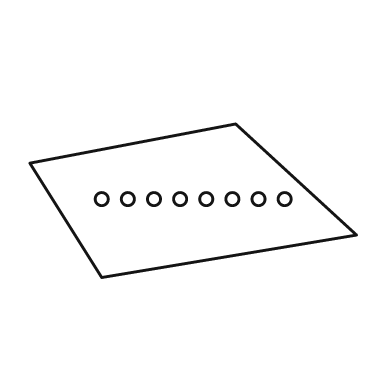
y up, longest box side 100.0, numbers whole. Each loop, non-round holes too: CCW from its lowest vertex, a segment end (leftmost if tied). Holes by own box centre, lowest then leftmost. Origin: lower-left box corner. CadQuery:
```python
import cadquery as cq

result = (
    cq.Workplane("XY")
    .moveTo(22.0, 0.0)
    .lineTo(100.0, 13.0)
    .lineTo(63.0, 47.0)
    .lineTo(0.0, 35.0)
    .close()
    .moveTo(22.0, 24.0)
    .circle(2.0)
    .moveTo(30.0, 24.0)
    .circle(2.0)
    .moveTo(38.0, 24.0)
    .circle(2.0)
    .moveTo(46.0, 24.0)
    .circle(2.0)
    .moveTo(54.0, 24.0)
    .circle(2.0)
    .moveTo(62.0, 24.0)
    .circle(2.0)
    .moveTo(70.0, 24.0)
    .circle(2.0)
    .moveTo(78.0, 24.0)
    .circle(2.0)
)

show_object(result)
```